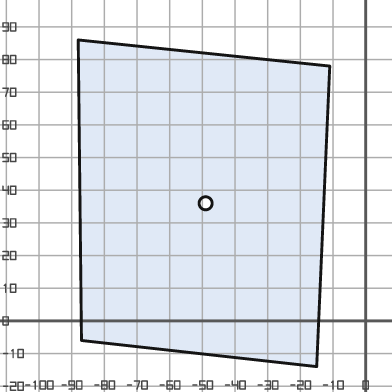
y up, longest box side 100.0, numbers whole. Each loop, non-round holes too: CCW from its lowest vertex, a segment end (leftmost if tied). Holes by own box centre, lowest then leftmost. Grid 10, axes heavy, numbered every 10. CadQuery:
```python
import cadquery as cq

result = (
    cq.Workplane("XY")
    .moveTo(-15.0, -14.0)
    .lineTo(-11.0, 78.0)
    .lineTo(-88.0, 86.0)
    .lineTo(-87.0, -6.0)
    .close()
    .moveTo(-49.0, 36.0)
    .circle(2.0)
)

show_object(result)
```